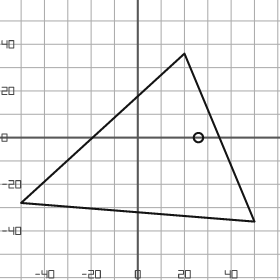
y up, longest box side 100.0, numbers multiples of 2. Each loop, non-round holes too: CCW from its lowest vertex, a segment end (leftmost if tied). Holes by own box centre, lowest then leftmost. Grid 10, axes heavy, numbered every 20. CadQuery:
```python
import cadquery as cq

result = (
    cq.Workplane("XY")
    .moveTo(50.0, -36.0)
    .lineTo(20.0, 36.0)
    .lineTo(-50.0, -28.0)
    .close()
    .moveTo(26.0, 0.0)
    .circle(2.0)
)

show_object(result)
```